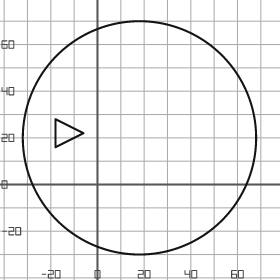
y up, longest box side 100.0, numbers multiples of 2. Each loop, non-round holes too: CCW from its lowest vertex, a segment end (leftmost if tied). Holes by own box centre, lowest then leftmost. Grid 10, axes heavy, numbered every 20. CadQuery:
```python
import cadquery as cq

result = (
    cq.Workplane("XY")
    .moveTo(18.0, 20.0)
    .circle(50.0)
    .moveTo(-18.0, 16.0)
    .lineTo(-6.0, 22.0)
    .lineTo(-18.0, 28.0)
    .close()
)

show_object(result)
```